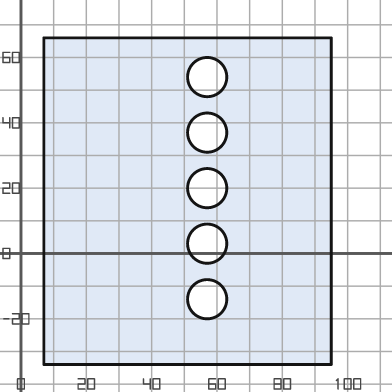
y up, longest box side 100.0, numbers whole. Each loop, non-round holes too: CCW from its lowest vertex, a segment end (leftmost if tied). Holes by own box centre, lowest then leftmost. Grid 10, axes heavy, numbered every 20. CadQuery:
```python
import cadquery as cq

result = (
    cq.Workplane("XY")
    .moveTo(7.0, -34.0)
    .lineTo(95.0, -34.0)
    .lineTo(95.0, 66.0)
    .lineTo(7.0, 66.0)
    .close()
    .moveTo(57.0, -14.0)
    .circle(6.0)
    .moveTo(57.0, 3.0)
    .circle(6.0)
    .moveTo(57.0, 20.0)
    .circle(6.0)
    .moveTo(57.0, 37.0)
    .circle(6.0)
    .moveTo(57.0, 54.0)
    .circle(6.0)
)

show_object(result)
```